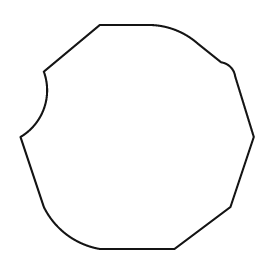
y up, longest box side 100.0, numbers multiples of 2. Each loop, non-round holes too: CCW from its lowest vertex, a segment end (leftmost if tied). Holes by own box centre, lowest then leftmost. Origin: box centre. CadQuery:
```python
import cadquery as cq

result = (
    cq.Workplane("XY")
    .moveTo(-16.0, -48.0)
    .lineTo(16.0, -48.0)
    .lineTo(40.0, -30.0)
    .lineTo(50.0, 0.0)
    .lineTo(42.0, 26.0)
    .threePointArc((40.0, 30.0), (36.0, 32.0))
    .lineTo(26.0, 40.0)
    .threePointArc((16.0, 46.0), (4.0, 48.0))
    .lineTo(-16.0, 48.0)
    .lineTo(-40.0, 28.0)
    .threePointArc((-40.0, 12.0), (-50.0, 0.0))
    .lineTo(-40.0, -30.0)
    .threePointArc((-30.0, -42.0), (-16.0, -48.0))
    .close()
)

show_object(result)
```